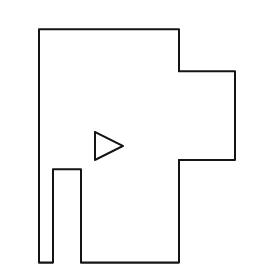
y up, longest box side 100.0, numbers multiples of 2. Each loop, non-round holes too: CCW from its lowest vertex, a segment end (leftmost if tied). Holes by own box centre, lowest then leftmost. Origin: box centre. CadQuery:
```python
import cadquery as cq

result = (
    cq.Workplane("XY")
    .moveTo(-42.0, -50.0)
    .lineTo(-36.0, -50.0)
    .lineTo(-36.0, -10.0)
    .lineTo(-24.0, -10.0)
    .lineTo(-24.0, -50.0)
    .lineTo(18.0, -50.0)
    .lineTo(18.0, -6.0)
    .lineTo(42.0, -6.0)
    .lineTo(42.0, 32.0)
    .lineTo(18.0, 32.0)
    .lineTo(18.0, 50.0)
    .lineTo(-42.0, 50.0)
    .close()
    .moveTo(-18.0, -6.0)
    .lineTo(-6.0, 0.0)
    .lineTo(-18.0, 6.0)
    .close()
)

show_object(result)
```